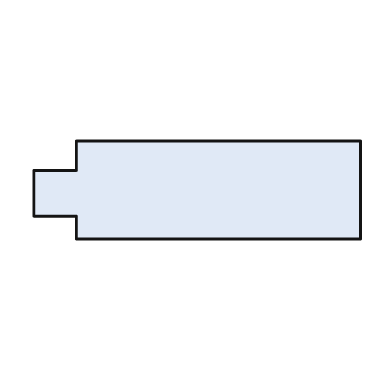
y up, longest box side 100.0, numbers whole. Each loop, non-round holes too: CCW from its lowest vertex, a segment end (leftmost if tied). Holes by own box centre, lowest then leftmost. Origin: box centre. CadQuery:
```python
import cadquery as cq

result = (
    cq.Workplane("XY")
    .moveTo(-37.0, -15.0)
    .lineTo(50.0, -15.0)
    .lineTo(50.0, 15.0)
    .lineTo(-37.0, 15.0)
    .lineTo(-37.0, 6.0)
    .lineTo(-50.0, 6.0)
    .lineTo(-50.0, -8.0)
    .lineTo(-37.0, -8.0)
    .close()
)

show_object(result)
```